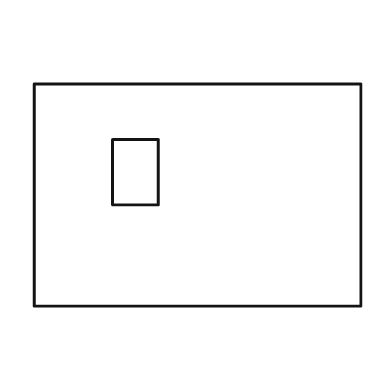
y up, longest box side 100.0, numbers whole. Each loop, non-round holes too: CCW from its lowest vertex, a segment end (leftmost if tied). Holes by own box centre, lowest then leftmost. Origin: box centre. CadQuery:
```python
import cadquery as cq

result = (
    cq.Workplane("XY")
    .moveTo(-50.0, -34.0)
    .lineTo(50.0, -34.0)
    .lineTo(50.0, 34.0)
    .lineTo(-50.0, 34.0)
    .close()
    .moveTo(-26.0, -3.0)
    .lineTo(-12.0, -3.0)
    .lineTo(-12.0, 17.0)
    .lineTo(-26.0, 17.0)
    .close()
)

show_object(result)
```